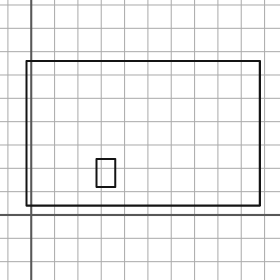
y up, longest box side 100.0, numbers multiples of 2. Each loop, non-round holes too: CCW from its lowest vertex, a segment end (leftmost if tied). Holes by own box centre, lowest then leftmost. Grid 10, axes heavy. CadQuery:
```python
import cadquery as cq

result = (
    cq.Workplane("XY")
    .moveTo(-2.0, 4.0)
    .lineTo(98.0, 4.0)
    .lineTo(98.0, 66.0)
    .lineTo(-2.0, 66.0)
    .close()
    .moveTo(28.0, 12.0)
    .lineTo(36.0, 12.0)
    .lineTo(36.0, 24.0)
    .lineTo(28.0, 24.0)
    .close()
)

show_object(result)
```